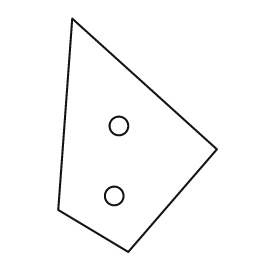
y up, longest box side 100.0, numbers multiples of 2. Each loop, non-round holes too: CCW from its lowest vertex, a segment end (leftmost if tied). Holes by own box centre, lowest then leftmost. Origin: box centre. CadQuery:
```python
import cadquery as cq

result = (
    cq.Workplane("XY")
    .moveTo(-4.0, -50.0)
    .lineTo(34.0, -6.0)
    .lineTo(-28.0, 50.0)
    .lineTo(-34.0, -32.0)
    .close()
    .moveTo(-10.0, -26.0)
    .circle(4.0)
    .moveTo(-8.0, 4.0)
    .circle(4.0)
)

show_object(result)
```